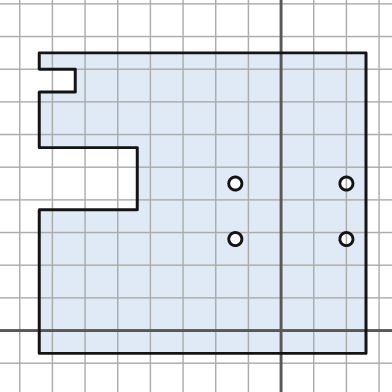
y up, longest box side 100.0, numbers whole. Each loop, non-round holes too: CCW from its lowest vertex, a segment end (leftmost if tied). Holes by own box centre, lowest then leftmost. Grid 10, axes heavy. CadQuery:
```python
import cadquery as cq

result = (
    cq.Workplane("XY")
    .moveTo(-74.0, -7.0)
    .lineTo(26.0, -7.0)
    .lineTo(26.0, 85.0)
    .lineTo(-74.0, 85.0)
    .lineTo(-74.0, 80.0)
    .lineTo(-63.0, 80.0)
    .lineTo(-63.0, 73.0)
    .lineTo(-74.0, 73.0)
    .lineTo(-74.0, 56.0)
    .lineTo(-44.0, 56.0)
    .lineTo(-44.0, 37.0)
    .lineTo(-74.0, 37.0)
    .close()
    .moveTo(-14.0, 28.0)
    .circle(2.0)
    .moveTo(20.0, 28.0)
    .circle(2.0)
    .moveTo(-14.0, 45.0)
    .circle(2.0)
    .moveTo(20.0, 45.0)
    .circle(2.0)
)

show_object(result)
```